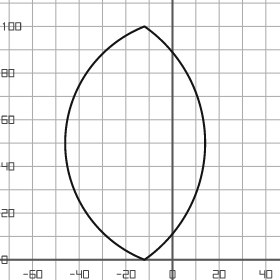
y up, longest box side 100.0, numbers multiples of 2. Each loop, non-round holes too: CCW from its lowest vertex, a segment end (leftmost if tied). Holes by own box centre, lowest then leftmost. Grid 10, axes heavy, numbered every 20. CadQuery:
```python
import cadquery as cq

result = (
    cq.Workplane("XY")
    .moveTo(-12.0, 0.0)
    .threePointArc((14.0, 50.0), (-12.0, 100.0))
    .threePointArc((-46.0, 50.0), (-12.0, 0.0))
    .close()
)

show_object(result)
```